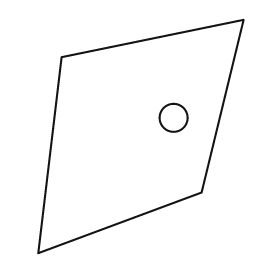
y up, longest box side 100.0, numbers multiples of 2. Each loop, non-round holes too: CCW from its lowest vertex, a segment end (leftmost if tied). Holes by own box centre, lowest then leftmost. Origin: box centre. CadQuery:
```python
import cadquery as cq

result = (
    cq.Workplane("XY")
    .moveTo(-44.0, -50.0)
    .lineTo(26.0, -24.0)
    .lineTo(44.0, 50.0)
    .lineTo(-34.0, 34.0)
    .close()
    .moveTo(14.0, 8.0)
    .circle(6.0)
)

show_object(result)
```